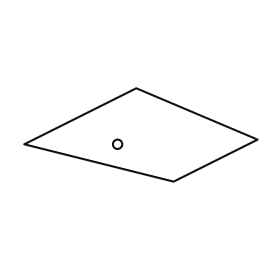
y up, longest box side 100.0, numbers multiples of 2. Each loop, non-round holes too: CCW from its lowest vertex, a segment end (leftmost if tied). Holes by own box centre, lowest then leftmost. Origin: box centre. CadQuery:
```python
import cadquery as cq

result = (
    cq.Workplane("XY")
    .moveTo(14.0, -20.0)
    .lineTo(50.0, -2.0)
    .lineTo(-2.0, 20.0)
    .lineTo(-50.0, -4.0)
    .close()
    .moveTo(-10.0, -4.0)
    .circle(2.0)
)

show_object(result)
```